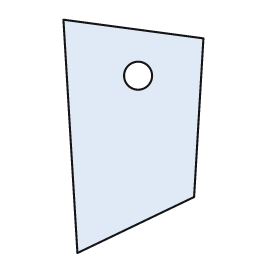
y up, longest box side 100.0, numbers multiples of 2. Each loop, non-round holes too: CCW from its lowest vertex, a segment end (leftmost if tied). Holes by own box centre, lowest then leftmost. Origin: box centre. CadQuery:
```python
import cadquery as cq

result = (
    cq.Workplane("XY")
    .moveTo(-24.0, -50.0)
    .lineTo(26.0, -26.0)
    .lineTo(30.0, 42.0)
    .lineTo(-30.0, 50.0)
    .close()
    .moveTo(2.0, 26.0)
    .circle(6.0)
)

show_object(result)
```